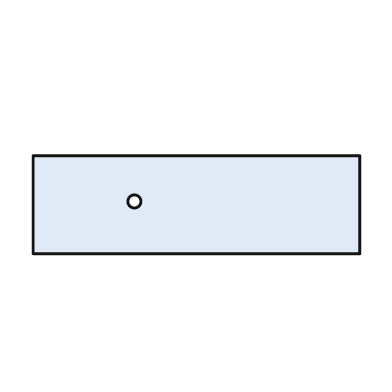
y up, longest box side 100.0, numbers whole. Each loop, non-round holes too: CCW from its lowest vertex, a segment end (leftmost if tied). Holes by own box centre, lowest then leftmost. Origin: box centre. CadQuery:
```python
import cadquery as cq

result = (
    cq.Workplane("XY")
    .moveTo(-50.0, -15.0)
    .lineTo(50.0, -15.0)
    .lineTo(50.0, 15.0)
    .lineTo(-50.0, 15.0)
    .close()
    .moveTo(-19.0, 1.0)
    .circle(2.0)
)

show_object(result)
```